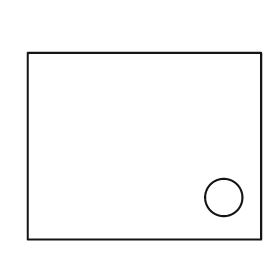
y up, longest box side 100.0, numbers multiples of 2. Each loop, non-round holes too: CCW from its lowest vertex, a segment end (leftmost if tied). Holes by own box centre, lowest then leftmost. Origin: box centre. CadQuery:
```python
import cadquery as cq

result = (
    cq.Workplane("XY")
    .moveTo(-50.0, -40.0)
    .lineTo(50.0, -40.0)
    .lineTo(50.0, 40.0)
    .lineTo(-50.0, 40.0)
    .close()
    .moveTo(34.0, -22.0)
    .circle(8.0)
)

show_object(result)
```